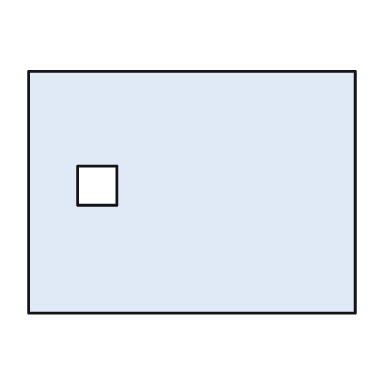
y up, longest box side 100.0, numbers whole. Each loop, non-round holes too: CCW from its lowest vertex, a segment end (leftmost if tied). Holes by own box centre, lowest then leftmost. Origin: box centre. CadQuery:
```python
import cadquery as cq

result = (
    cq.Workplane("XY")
    .moveTo(-50.0, -37.0)
    .lineTo(50.0, -37.0)
    .lineTo(50.0, 37.0)
    .lineTo(-50.0, 37.0)
    .close()
    .moveTo(-35.0, -4.0)
    .lineTo(-23.0, -4.0)
    .lineTo(-23.0, 8.0)
    .lineTo(-35.0, 8.0)
    .close()
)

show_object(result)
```